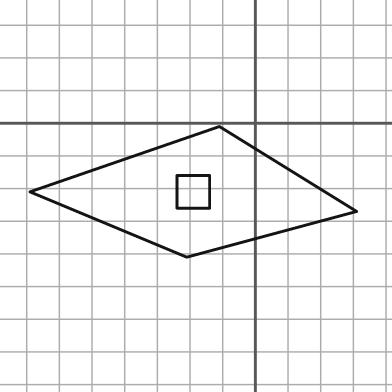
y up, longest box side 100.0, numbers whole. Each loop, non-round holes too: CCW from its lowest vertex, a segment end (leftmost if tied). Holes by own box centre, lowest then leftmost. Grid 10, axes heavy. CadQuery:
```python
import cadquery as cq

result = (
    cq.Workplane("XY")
    .moveTo(-21.0, -41.0)
    .lineTo(31.0, -27.0)
    .lineTo(-11.0, -1.0)
    .lineTo(-69.0, -21.0)
    .close()
    .moveTo(-24.0, -26.0)
    .lineTo(-14.0, -26.0)
    .lineTo(-14.0, -16.0)
    .lineTo(-24.0, -16.0)
    .close()
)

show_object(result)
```